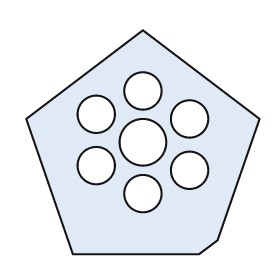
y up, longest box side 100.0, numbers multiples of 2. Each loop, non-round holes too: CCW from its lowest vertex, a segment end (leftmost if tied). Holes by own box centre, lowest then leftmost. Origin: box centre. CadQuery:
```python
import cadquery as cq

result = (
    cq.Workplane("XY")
    .moveTo(-30.0, -48.0)
    .lineTo(24.0, -48.0)
    .lineTo(32.0, -42.0)
    .lineTo(50.0, 10.0)
    .lineTo(0.0, 48.0)
    .lineTo(-50.0, 10.0)
    .close()
    .moveTo(0.0, -22.0)
    .circle(8.0)
    .moveTo(20.0, -12.0)
    .circle(8.0)
    .moveTo(-20.0, -10.0)
    .circle(8.0)
    .moveTo(0.0, 0.0)
    .circle(10.0)
    .moveTo(20.0, 10.0)
    .circle(8.0)
    .moveTo(-20.0, 12.0)
    .circle(8.0)
    .moveTo(0.0, 22.0)
    .circle(8.0)
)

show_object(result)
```